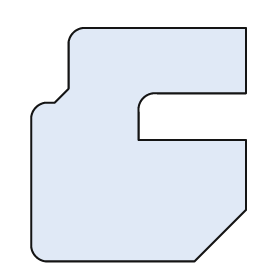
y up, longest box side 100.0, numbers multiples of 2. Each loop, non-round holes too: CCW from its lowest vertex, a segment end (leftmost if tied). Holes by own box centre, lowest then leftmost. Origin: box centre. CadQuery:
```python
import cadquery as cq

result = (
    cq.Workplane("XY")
    .moveTo(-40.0, -50.0)
    .lineTo(24.0, -50.0)
    .lineTo(46.0, -28.0)
    .lineTo(46.0, 2.0)
    .lineTo(0.0, 2.0)
    .lineTo(0.0, 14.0)
    .threePointArc((2.0, 20.0), (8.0, 22.0))
    .lineTo(46.0, 22.0)
    .lineTo(46.0, 50.0)
    .lineTo(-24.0, 50.0)
    .threePointArc((-28.0, 48.0), (-30.0, 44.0))
    .lineTo(-30.0, 24.0)
    .lineTo(-36.0, 18.0)
    .lineTo(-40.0, 18.0)
    .threePointArc((-44.0, 16.0), (-46.0, 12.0))
    .lineTo(-46.0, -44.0)
    .threePointArc((-44.0, -48.0), (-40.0, -50.0))
    .close()
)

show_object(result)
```